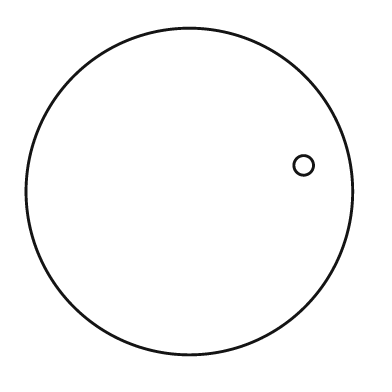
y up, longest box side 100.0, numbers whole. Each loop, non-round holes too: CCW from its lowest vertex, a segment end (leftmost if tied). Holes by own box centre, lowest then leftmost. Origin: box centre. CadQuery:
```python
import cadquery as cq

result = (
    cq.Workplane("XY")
    .moveTo(0.0, 0.0)
    .circle(50.0)
    .moveTo(35.0, 8.0)
    .circle(3.0)
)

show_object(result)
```